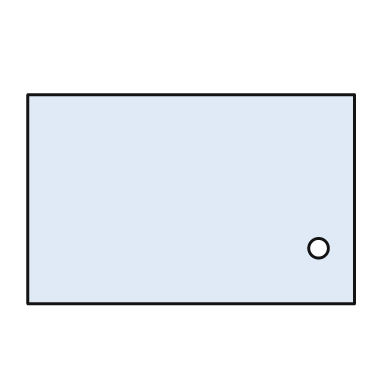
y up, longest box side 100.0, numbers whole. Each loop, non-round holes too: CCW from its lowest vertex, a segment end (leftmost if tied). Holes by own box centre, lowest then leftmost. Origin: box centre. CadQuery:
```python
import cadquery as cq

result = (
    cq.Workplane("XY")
    .moveTo(-50.0, -32.0)
    .lineTo(50.0, -32.0)
    .lineTo(50.0, 32.0)
    .lineTo(-50.0, 32.0)
    .close()
    .moveTo(39.0, -15.0)
    .circle(3.0)
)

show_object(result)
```